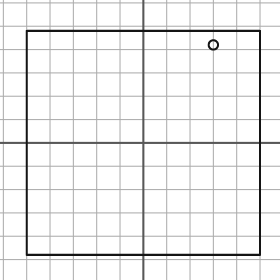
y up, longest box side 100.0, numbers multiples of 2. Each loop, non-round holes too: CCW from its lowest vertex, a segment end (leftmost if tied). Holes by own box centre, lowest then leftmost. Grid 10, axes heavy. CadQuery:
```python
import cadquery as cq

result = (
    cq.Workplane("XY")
    .moveTo(-50.0, -48.0)
    .lineTo(50.0, -48.0)
    .lineTo(50.0, 48.0)
    .lineTo(-50.0, 48.0)
    .close()
    .moveTo(30.0, 42.0)
    .circle(2.0)
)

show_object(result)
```